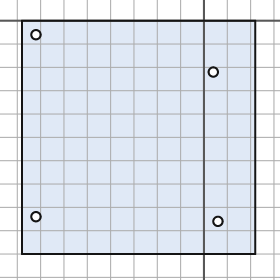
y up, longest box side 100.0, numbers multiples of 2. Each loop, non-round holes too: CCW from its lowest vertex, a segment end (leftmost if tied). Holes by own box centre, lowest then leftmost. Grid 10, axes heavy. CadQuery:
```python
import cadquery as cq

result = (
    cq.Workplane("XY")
    .moveTo(-78.0, -100.0)
    .lineTo(22.0, -100.0)
    .lineTo(22.0, 0.0)
    .lineTo(-78.0, 0.0)
    .close()
    .moveTo(6.0, -86.0)
    .circle(2.0)
    .moveTo(-72.0, -84.0)
    .circle(2.0)
    .moveTo(4.0, -22.0)
    .circle(2.0)
    .moveTo(-72.0, -6.0)
    .circle(2.0)
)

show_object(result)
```